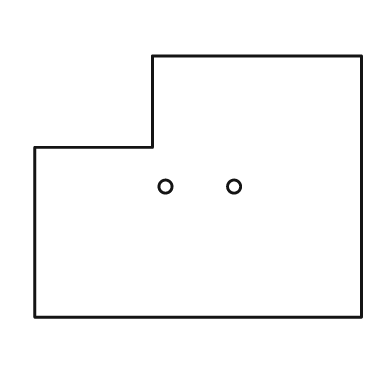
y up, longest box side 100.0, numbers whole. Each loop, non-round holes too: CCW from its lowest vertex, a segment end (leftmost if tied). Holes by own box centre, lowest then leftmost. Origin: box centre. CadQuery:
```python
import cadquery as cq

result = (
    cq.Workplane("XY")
    .moveTo(-50.0, -40.0)
    .lineTo(50.0, -40.0)
    .lineTo(50.0, 40.0)
    .lineTo(-14.0, 40.0)
    .lineTo(-14.0, 12.0)
    .lineTo(-50.0, 12.0)
    .close()
    .moveTo(-10.0, 0.0)
    .circle(2.0)
    .moveTo(11.0, 0.0)
    .circle(2.0)
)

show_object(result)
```